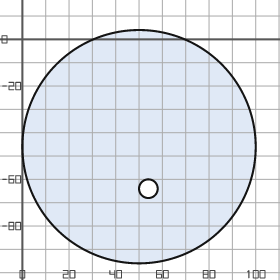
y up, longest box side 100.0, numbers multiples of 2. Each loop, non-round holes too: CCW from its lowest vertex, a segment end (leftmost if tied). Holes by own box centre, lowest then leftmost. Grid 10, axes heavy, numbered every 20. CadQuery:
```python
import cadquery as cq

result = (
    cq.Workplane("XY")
    .moveTo(50.0, -46.0)
    .circle(50.0)
    .moveTo(54.0, -64.0)
    .circle(4.0)
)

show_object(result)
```